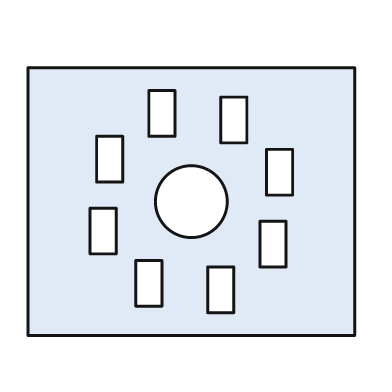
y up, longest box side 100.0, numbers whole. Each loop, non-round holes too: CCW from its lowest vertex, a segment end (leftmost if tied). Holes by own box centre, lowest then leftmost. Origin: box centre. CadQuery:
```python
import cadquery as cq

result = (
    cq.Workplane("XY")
    .moveTo(-50.0, -41.0)
    .lineTo(50.0, -41.0)
    .lineTo(50.0, 41.0)
    .lineTo(-50.0, 41.0)
    .close()
    .moveTo(5.0, -34.0)
    .lineTo(13.0, -34.0)
    .lineTo(13.0, -20.0)
    .lineTo(5.0, -20.0)
    .close()
    .moveTo(-17.0, -32.0)
    .lineTo(-9.0, -32.0)
    .lineTo(-9.0, -18.0)
    .lineTo(-17.0, -18.0)
    .close()
    .moveTo(21.0, -20.0)
    .lineTo(29.0, -20.0)
    .lineTo(29.0, -6.0)
    .lineTo(21.0, -6.0)
    .close()
    .moveTo(-31.0, -16.0)
    .lineTo(-23.0, -16.0)
    .lineTo(-23.0, -2.0)
    .lineTo(-31.0, -2.0)
    .close()
    .moveTo(0.0, 0.0)
    .circle(11.0)
    .moveTo(23.0, 2.0)
    .lineTo(31.0, 2.0)
    .lineTo(31.0, 16.0)
    .lineTo(23.0, 16.0)
    .close()
    .moveTo(-29.0, 6.0)
    .lineTo(-21.0, 6.0)
    .lineTo(-21.0, 20.0)
    .lineTo(-29.0, 20.0)
    .close()
    .moveTo(9.0, 18.0)
    .lineTo(17.0, 18.0)
    .lineTo(17.0, 32.0)
    .lineTo(9.0, 32.0)
    .close()
    .moveTo(-13.0, 20.0)
    .lineTo(-5.0, 20.0)
    .lineTo(-5.0, 34.0)
    .lineTo(-13.0, 34.0)
    .close()
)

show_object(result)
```